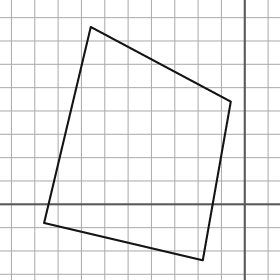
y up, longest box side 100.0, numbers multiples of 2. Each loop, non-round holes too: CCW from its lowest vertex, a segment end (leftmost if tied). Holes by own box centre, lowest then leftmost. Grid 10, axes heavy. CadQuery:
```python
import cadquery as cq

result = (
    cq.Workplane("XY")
    .moveTo(-18.0, -24.0)
    .lineTo(-6.0, 44.0)
    .lineTo(-66.0, 76.0)
    .lineTo(-86.0, -8.0)
    .close()
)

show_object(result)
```